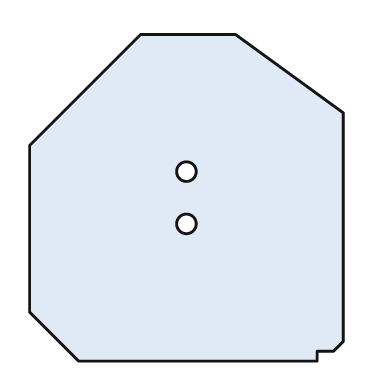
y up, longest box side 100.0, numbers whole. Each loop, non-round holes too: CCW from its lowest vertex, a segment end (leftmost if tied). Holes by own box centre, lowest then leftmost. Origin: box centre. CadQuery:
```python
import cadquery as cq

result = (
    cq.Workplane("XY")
    .moveTo(-33.0, -50.0)
    .lineTo(40.0, -50.0)
    .lineTo(40.0, -47.0)
    .lineTo(45.0, -47.0)
    .lineTo(48.0, -44.0)
    .lineTo(48.0, 26.0)
    .lineTo(15.0, 50.0)
    .lineTo(-14.0, 50.0)
    .lineTo(-48.0, 16.0)
    .lineTo(-48.0, -35.0)
    .close()
    .moveTo(0.0, -8.0)
    .circle(3.0)
    .moveTo(0.0, 8.0)
    .circle(3.0)
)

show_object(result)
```